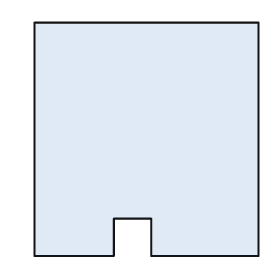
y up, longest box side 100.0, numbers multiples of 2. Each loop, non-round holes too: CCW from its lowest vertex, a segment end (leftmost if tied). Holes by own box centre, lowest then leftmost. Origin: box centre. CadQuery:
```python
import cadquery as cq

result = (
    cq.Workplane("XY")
    .moveTo(-48.0, -50.0)
    .lineTo(-14.0, -50.0)
    .lineTo(-14.0, -34.0)
    .lineTo(2.0, -34.0)
    .lineTo(2.0, -50.0)
    .lineTo(48.0, -50.0)
    .lineTo(48.0, 50.0)
    .lineTo(-48.0, 50.0)
    .close()
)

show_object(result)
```